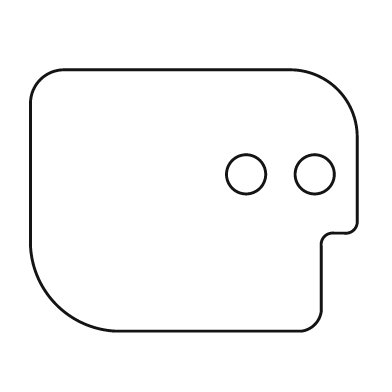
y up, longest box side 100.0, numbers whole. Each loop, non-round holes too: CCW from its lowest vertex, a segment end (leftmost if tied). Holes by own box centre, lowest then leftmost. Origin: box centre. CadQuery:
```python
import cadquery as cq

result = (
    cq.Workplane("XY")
    .moveTo(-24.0, -40.0)
    .lineTo(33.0, -40.0)
    .threePointArc((37.0, -38.0), (39.0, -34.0))
    .lineTo(39.0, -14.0)
    .threePointArc((40.0, -11.0), (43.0, -10.0))
    .lineTo(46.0, -10.0)
    .threePointArc((49.0, -9.0), (50.0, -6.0))
    .lineTo(50.0, 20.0)
    .threePointArc((44.0, 34.0), (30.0, 40.0))
    .lineTo(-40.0, 40.0)
    .threePointArc((-47.0, 37.0), (-50.0, 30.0))
    .lineTo(-50.0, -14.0)
    .threePointArc((-42.0, -32.0), (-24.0, -40.0))
    .close()
    .moveTo(16.0, 8.0)
    .circle(6.0)
    .moveTo(37.0, 8.0)
    .circle(6.0)
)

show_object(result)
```